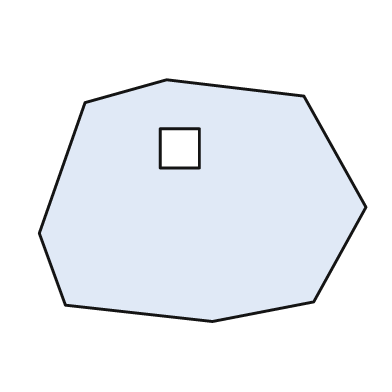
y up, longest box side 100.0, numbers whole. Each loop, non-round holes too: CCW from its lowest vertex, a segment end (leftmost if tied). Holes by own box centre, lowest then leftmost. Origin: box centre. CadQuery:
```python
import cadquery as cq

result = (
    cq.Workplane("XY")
    .moveTo(3.0, -37.0)
    .lineTo(34.0, -31.0)
    .lineTo(50.0, -2.0)
    .lineTo(31.0, 32.0)
    .lineTo(-11.0, 37.0)
    .lineTo(-36.0, 30.0)
    .lineTo(-50.0, -10.0)
    .lineTo(-42.0, -32.0)
    .close()
    .moveTo(-13.0, 10.0)
    .lineTo(-1.0, 10.0)
    .lineTo(-1.0, 22.0)
    .lineTo(-13.0, 22.0)
    .close()
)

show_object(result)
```